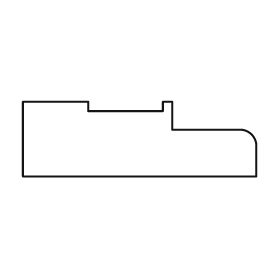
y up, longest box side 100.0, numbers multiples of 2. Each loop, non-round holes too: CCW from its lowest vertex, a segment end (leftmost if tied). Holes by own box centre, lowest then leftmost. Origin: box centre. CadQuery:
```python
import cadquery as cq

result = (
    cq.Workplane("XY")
    .moveTo(-50.0, -16.0)
    .lineTo(50.0, -16.0)
    .lineTo(50.0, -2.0)
    .threePointArc((48.0, 2.0), (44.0, 4.0))
    .lineTo(14.0, 4.0)
    .lineTo(14.0, 16.0)
    .lineTo(10.0, 16.0)
    .lineTo(10.0, 12.0)
    .lineTo(-22.0, 12.0)
    .lineTo(-22.0, 16.0)
    .lineTo(-50.0, 16.0)
    .close()
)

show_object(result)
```